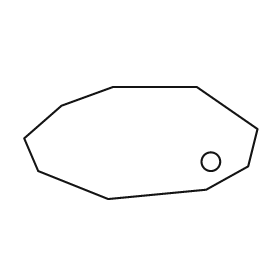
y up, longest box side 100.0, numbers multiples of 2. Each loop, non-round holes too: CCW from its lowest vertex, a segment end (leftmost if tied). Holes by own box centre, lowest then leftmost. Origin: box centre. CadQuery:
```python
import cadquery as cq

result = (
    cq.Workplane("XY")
    .moveTo(-14.0, -24.0)
    .lineTo(28.0, -20.0)
    .lineTo(46.0, -10.0)
    .lineTo(50.0, 6.0)
    .lineTo(24.0, 24.0)
    .lineTo(-12.0, 24.0)
    .lineTo(-34.0, 16.0)
    .lineTo(-50.0, 2.0)
    .lineTo(-44.0, -12.0)
    .close()
    .moveTo(30.0, -8.0)
    .circle(4.0)
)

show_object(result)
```